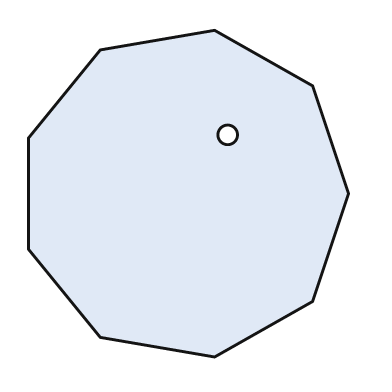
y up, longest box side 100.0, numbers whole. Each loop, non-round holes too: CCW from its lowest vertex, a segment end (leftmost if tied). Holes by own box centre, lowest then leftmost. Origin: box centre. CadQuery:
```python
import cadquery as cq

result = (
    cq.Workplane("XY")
    .moveTo(8.0, -50.0)
    .lineTo(38.0, -33.0)
    .lineTo(49.0, 0.0)
    .lineTo(38.0, 33.0)
    .lineTo(8.0, 50.0)
    .lineTo(-27.0, 44.0)
    .lineTo(-49.0, 17.0)
    .lineTo(-49.0, -17.0)
    .lineTo(-27.0, -44.0)
    .close()
    .moveTo(12.0, 18.0)
    .circle(3.0)
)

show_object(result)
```